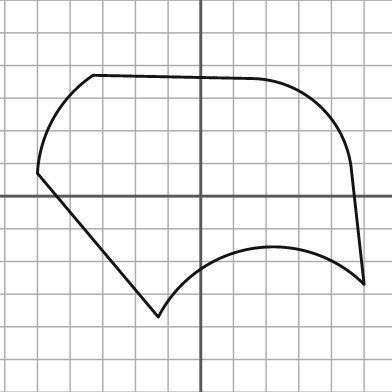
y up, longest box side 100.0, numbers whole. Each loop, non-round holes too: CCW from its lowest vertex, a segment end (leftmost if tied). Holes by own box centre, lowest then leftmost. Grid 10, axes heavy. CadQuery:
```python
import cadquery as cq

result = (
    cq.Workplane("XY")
    .moveTo(-13.0, -37.0)
    .threePointArc((16.0, -16.0), (50.0, -27.0))
    .lineTo(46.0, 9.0)
    .threePointArc((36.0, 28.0), (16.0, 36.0))
    .lineTo(-33.0, 37.0)
    .threePointArc((-45.0, 24.0), (-50.0, 7.0))
    .close()
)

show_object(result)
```